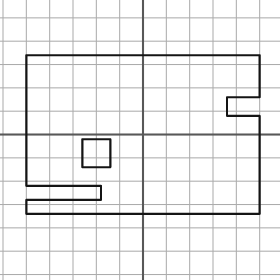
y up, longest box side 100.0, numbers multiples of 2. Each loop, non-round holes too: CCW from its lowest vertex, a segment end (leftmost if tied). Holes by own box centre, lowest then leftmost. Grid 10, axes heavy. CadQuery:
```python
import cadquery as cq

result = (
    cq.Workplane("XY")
    .moveTo(-50.0, -34.0)
    .lineTo(50.0, -34.0)
    .lineTo(50.0, 8.0)
    .lineTo(36.0, 8.0)
    .lineTo(36.0, 16.0)
    .lineTo(50.0, 16.0)
    .lineTo(50.0, 34.0)
    .lineTo(-50.0, 34.0)
    .lineTo(-50.0, -22.0)
    .lineTo(-18.0, -22.0)
    .lineTo(-18.0, -28.0)
    .lineTo(-50.0, -28.0)
    .close()
    .moveTo(-26.0, -14.0)
    .lineTo(-14.0, -14.0)
    .lineTo(-14.0, -2.0)
    .lineTo(-26.0, -2.0)
    .close()
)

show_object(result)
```